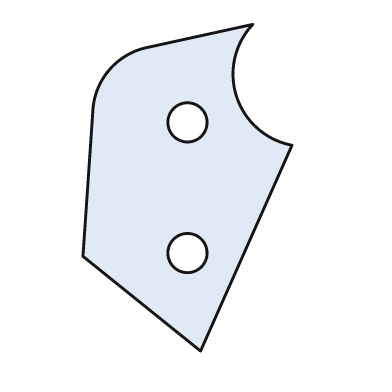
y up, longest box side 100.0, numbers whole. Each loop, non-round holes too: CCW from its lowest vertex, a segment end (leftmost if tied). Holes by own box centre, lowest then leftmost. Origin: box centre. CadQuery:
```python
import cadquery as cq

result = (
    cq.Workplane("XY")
    .moveTo(4.0, -50.0)
    .lineTo(32.0, 13.0)
    .threePointArc((15.0, 28.0), (20.0, 50.0))
    .lineTo(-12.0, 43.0)
    .threePointArc((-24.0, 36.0), (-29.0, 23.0))
    .lineTo(-32.0, -21.0)
    .close()
    .moveTo(0.0, -20.0)
    .circle(6.0)
    .moveTo(0.0, 20.0)
    .circle(6.0)
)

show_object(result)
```